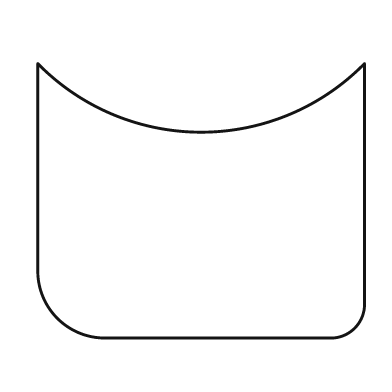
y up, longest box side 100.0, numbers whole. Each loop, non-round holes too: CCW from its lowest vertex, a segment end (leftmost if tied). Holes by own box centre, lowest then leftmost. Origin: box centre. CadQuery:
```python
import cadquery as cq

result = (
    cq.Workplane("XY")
    .moveTo(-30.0, -42.0)
    .lineTo(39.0, -42.0)
    .threePointArc((47.0, -39.0), (50.0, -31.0))
    .lineTo(50.0, 42.0)
    .threePointArc((0.0, 21.0), (-50.0, 42.0))
    .lineTo(-50.0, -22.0)
    .threePointArc((-44.0, -36.0), (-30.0, -42.0))
    .close()
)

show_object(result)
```